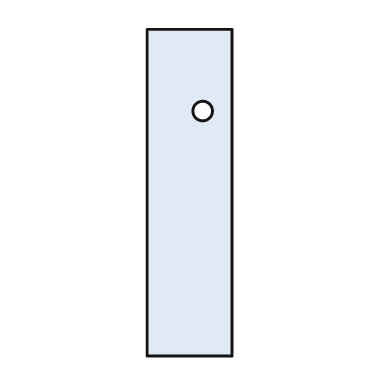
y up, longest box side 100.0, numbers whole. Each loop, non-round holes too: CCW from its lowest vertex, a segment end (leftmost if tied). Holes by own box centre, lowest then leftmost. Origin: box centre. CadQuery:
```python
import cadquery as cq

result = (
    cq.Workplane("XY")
    .moveTo(-13.0, -50.0)
    .lineTo(13.0, -50.0)
    .lineTo(13.0, 50.0)
    .lineTo(-13.0, 50.0)
    .close()
    .moveTo(4.0, 25.0)
    .circle(3.0)
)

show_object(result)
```